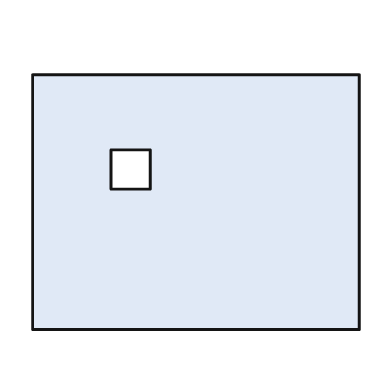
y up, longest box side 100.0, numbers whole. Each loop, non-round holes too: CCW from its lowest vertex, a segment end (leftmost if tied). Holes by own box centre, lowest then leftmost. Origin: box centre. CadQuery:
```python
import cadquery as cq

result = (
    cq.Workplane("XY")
    .moveTo(-50.0, -39.0)
    .lineTo(50.0, -39.0)
    .lineTo(50.0, 39.0)
    .lineTo(-50.0, 39.0)
    .close()
    .moveTo(-26.0, 4.0)
    .lineTo(-14.0, 4.0)
    .lineTo(-14.0, 16.0)
    .lineTo(-26.0, 16.0)
    .close()
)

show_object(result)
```